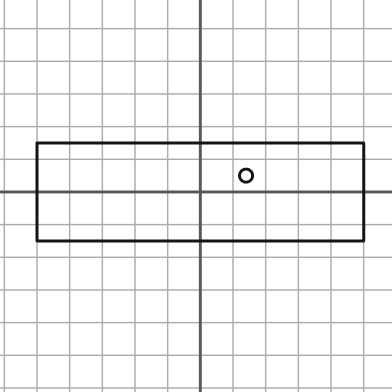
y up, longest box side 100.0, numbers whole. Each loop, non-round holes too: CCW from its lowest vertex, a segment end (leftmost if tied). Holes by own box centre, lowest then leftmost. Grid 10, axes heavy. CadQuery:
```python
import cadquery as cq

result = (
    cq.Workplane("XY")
    .moveTo(-50.0, -15.0)
    .lineTo(50.0, -15.0)
    .lineTo(50.0, 15.0)
    .lineTo(-50.0, 15.0)
    .close()
    .moveTo(14.0, 5.0)
    .circle(2.0)
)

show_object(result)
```